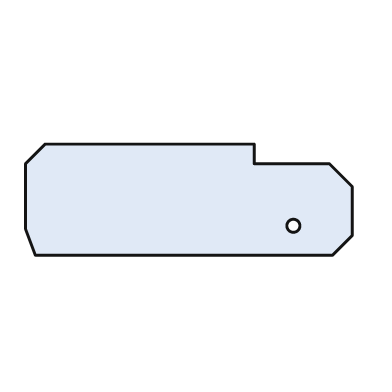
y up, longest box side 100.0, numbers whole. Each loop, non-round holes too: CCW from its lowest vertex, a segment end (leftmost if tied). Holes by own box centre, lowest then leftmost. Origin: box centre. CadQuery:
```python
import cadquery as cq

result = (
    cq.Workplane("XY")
    .moveTo(-47.0, -17.0)
    .lineTo(44.0, -17.0)
    .lineTo(50.0, -11.0)
    .lineTo(50.0, 4.0)
    .lineTo(43.0, 11.0)
    .lineTo(20.0, 11.0)
    .lineTo(20.0, 17.0)
    .lineTo(-44.0, 17.0)
    .lineTo(-50.0, 11.0)
    .lineTo(-50.0, -9.0)
    .close()
    .moveTo(32.0, -8.0)
    .circle(2.0)
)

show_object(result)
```